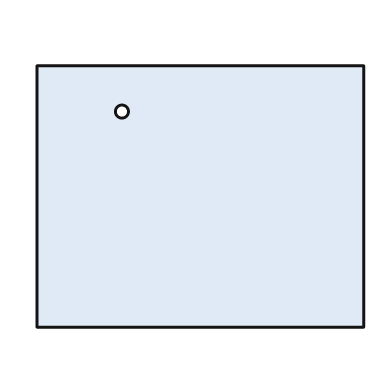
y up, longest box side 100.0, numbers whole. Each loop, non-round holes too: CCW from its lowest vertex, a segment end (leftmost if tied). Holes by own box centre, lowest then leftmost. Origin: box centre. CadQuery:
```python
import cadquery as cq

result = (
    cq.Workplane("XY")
    .moveTo(-50.0, -40.0)
    .lineTo(50.0, -40.0)
    .lineTo(50.0, 40.0)
    .lineTo(-50.0, 40.0)
    .close()
    .moveTo(-24.0, 26.0)
    .circle(2.0)
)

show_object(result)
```